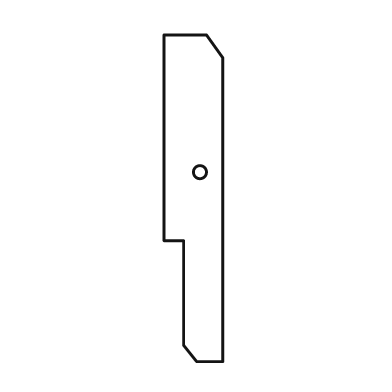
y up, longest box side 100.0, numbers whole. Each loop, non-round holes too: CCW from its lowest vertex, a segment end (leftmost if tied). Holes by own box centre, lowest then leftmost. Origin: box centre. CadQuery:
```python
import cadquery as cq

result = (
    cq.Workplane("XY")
    .moveTo(1.0, -50.0)
    .lineTo(9.0, -50.0)
    .lineTo(9.0, 43.0)
    .lineTo(4.0, 50.0)
    .lineTo(-9.0, 50.0)
    .lineTo(-9.0, -13.0)
    .lineTo(-3.0, -13.0)
    .lineTo(-3.0, -45.0)
    .close()
    .moveTo(2.0, 8.0)
    .circle(2.0)
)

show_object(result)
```